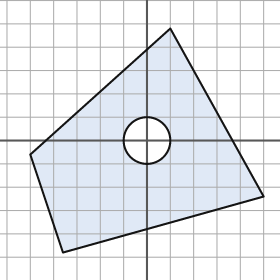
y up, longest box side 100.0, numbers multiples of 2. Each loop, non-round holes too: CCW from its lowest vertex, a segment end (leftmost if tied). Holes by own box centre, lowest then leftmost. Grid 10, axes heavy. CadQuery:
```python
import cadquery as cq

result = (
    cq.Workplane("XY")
    .moveTo(-36.0, -48.0)
    .lineTo(50.0, -24.0)
    .lineTo(10.0, 48.0)
    .lineTo(-50.0, -6.0)
    .close()
    .moveTo(0.0, 0.0)
    .circle(10.0)
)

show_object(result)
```